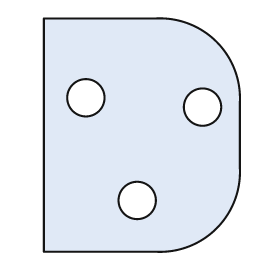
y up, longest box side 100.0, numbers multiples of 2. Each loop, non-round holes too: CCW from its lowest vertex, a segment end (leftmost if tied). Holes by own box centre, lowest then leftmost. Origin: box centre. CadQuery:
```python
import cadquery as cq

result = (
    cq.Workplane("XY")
    .moveTo(-42.0, -50.0)
    .lineTo(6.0, -50.0)
    .threePointArc((32.0, -40.0), (42.0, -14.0))
    .lineTo(42.0, 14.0)
    .threePointArc((32.0, 40.0), (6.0, 50.0))
    .lineTo(-42.0, 50.0)
    .close()
    .moveTo(-2.0, -28.0)
    .circle(8.0)
    .moveTo(26.0, 12.0)
    .circle(8.0)
    .moveTo(-24.0, 16.0)
    .circle(8.0)
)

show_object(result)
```